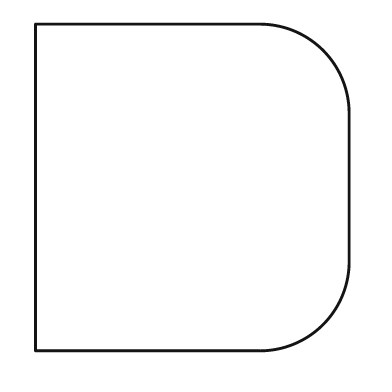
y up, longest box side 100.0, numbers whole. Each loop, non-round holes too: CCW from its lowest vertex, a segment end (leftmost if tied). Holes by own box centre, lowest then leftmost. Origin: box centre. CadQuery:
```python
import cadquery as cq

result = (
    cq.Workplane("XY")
    .moveTo(-48.0, -50.0)
    .lineTo(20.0, -50.0)
    .threePointArc((40.0, -42.0), (48.0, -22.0))
    .lineTo(48.0, 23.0)
    .threePointArc((40.0, 42.0), (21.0, 50.0))
    .lineTo(-48.0, 50.0)
    .close()
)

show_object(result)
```